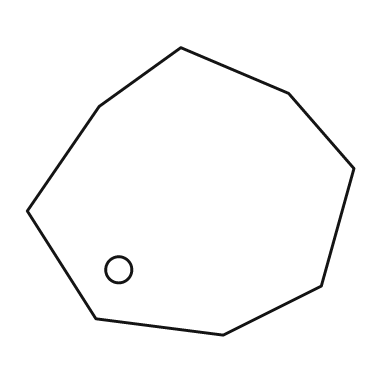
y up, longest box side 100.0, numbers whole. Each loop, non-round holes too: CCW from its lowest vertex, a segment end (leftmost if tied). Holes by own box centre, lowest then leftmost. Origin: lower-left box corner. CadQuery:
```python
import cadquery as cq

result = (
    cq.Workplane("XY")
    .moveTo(60.0, 0.0)
    .lineTo(90.0, 15.0)
    .lineTo(100.0, 51.0)
    .lineTo(80.0, 74.0)
    .lineTo(47.0, 88.0)
    .lineTo(22.0, 70.0)
    .lineTo(0.0, 38.0)
    .lineTo(21.0, 5.0)
    .close()
    .moveTo(28.0, 20.0)
    .circle(4.0)
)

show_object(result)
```